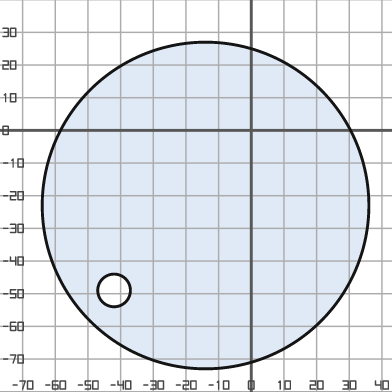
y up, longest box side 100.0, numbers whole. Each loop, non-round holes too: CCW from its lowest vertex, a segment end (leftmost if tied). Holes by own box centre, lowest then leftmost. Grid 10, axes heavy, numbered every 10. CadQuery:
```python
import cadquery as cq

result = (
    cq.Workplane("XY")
    .moveTo(-14.0, -23.0)
    .circle(50.0)
    .moveTo(-42.0, -49.0)
    .circle(5.0)
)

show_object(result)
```